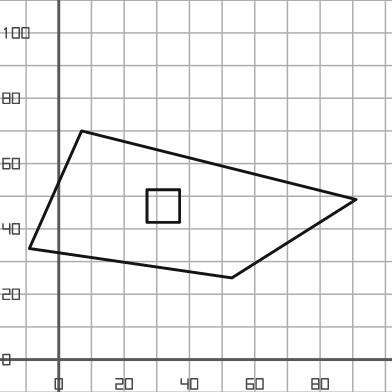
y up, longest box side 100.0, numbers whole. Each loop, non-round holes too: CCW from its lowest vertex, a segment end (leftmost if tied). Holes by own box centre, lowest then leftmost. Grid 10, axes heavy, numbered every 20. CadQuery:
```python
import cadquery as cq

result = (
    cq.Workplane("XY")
    .moveTo(53.0, 25.0)
    .lineTo(91.0, 49.0)
    .lineTo(7.0, 70.0)
    .lineTo(-9.0, 34.0)
    .close()
    .moveTo(27.0, 42.0)
    .lineTo(37.0, 42.0)
    .lineTo(37.0, 52.0)
    .lineTo(27.0, 52.0)
    .close()
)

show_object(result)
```